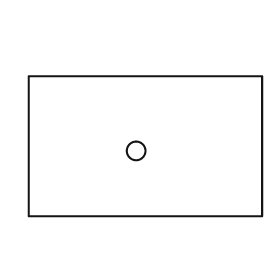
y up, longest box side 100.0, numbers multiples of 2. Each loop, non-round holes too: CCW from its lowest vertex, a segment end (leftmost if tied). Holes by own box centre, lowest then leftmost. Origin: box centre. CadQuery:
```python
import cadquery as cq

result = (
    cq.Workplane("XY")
    .moveTo(-50.0, -30.0)
    .lineTo(50.0, -30.0)
    .lineTo(50.0, 30.0)
    .lineTo(-50.0, 30.0)
    .close()
    .moveTo(-4.0, -2.0)
    .circle(4.0)
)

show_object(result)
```